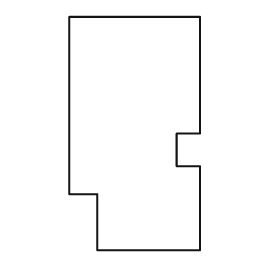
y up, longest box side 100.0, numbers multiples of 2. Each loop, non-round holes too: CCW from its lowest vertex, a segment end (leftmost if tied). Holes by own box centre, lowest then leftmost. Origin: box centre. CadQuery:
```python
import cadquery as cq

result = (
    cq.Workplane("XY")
    .moveTo(-16.0, -50.0)
    .lineTo(28.0, -50.0)
    .lineTo(28.0, -14.0)
    .lineTo(18.0, -14.0)
    .lineTo(18.0, 0.0)
    .lineTo(28.0, 0.0)
    .lineTo(28.0, 50.0)
    .lineTo(-28.0, 50.0)
    .lineTo(-28.0, -26.0)
    .lineTo(-16.0, -26.0)
    .close()
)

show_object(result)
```